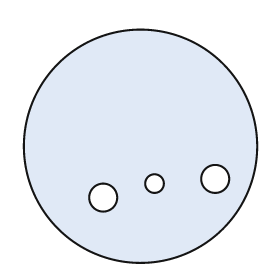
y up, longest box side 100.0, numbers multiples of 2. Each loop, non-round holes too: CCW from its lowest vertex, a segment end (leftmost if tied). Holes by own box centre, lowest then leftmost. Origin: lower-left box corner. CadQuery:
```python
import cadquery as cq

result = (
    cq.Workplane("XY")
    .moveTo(50.0, 50.0)
    .circle(50.0)
    .moveTo(34.0, 28.0)
    .circle(6.0)
    .moveTo(56.0, 34.0)
    .circle(4.0)
    .moveTo(82.0, 36.0)
    .circle(6.0)
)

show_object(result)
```